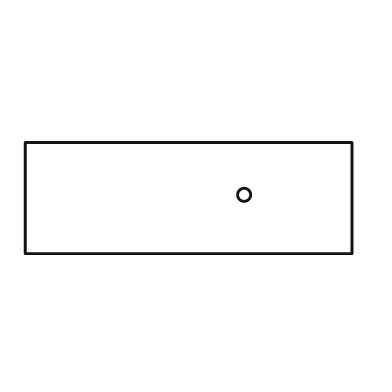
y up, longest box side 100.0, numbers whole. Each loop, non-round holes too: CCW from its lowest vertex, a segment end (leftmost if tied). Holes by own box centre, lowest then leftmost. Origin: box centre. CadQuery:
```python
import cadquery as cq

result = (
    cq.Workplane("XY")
    .moveTo(-50.0, -17.0)
    .lineTo(50.0, -17.0)
    .lineTo(50.0, 17.0)
    .lineTo(-50.0, 17.0)
    .close()
    .moveTo(17.0, 1.0)
    .circle(2.0)
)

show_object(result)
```